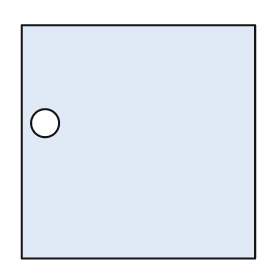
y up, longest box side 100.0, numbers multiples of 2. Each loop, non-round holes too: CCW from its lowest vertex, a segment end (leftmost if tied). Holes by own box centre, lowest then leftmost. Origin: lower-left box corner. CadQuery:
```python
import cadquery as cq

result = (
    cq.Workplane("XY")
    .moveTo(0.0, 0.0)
    .lineTo(100.0, 0.0)
    .lineTo(100.0, 100.0)
    .lineTo(0.0, 100.0)
    .close()
    .moveTo(10.0, 58.0)
    .circle(6.0)
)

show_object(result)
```